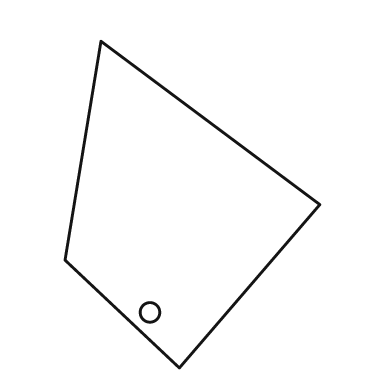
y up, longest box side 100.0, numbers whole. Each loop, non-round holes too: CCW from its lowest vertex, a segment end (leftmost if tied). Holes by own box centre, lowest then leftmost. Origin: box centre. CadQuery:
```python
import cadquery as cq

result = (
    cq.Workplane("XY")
    .moveTo(-4.0, -50.0)
    .lineTo(39.0, 0.0)
    .lineTo(-28.0, 50.0)
    .lineTo(-39.0, -17.0)
    .close()
    .moveTo(-13.0, -33.0)
    .circle(3.0)
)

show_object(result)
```